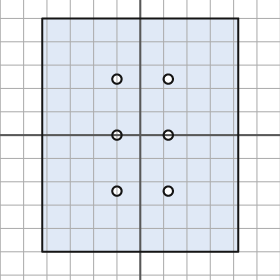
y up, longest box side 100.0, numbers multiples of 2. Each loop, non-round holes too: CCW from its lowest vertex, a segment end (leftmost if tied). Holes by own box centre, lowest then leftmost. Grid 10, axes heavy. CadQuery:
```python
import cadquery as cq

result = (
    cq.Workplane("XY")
    .moveTo(-42.0, -50.0)
    .lineTo(42.0, -50.0)
    .lineTo(42.0, 50.0)
    .lineTo(-42.0, 50.0)
    .close()
    .moveTo(-10.0, -24.0)
    .circle(2.0)
    .moveTo(12.0, -24.0)
    .circle(2.0)
    .moveTo(-10.0, 0.0)
    .circle(2.0)
    .moveTo(12.0, 0.0)
    .circle(2.0)
    .moveTo(-10.0, 24.0)
    .circle(2.0)
    .moveTo(12.0, 24.0)
    .circle(2.0)
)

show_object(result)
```